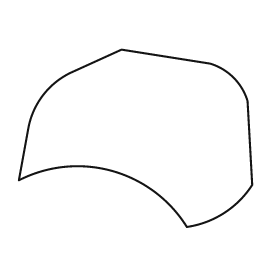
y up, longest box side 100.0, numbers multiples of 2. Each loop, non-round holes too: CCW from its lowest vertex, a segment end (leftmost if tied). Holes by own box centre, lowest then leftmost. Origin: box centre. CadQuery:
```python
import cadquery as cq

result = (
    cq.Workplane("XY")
    .moveTo(22.0, -38.0)
    .threePointArc((38.0, -32.0), (50.0, -20.0))
    .lineTo(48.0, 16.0)
    .threePointArc((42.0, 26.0), (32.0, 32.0))
    .lineTo(-6.0, 38.0)
    .lineTo(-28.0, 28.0)
    .threePointArc((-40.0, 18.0), (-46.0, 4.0))
    .lineTo(-50.0, -18.0)
    .threePointArc((-10.0, -14.0), (22.0, -38.0))
    .close()
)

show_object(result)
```